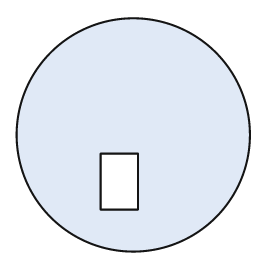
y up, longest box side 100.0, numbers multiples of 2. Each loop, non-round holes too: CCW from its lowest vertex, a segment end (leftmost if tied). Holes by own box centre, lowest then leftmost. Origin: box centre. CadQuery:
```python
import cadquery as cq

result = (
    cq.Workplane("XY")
    .moveTo(0.0, 0.0)
    .circle(50.0)
    .moveTo(-14.0, -32.0)
    .lineTo(2.0, -32.0)
    .lineTo(2.0, -8.0)
    .lineTo(-14.0, -8.0)
    .close()
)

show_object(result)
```